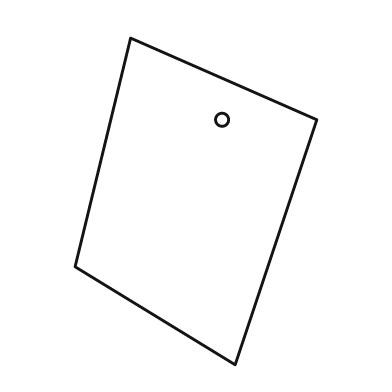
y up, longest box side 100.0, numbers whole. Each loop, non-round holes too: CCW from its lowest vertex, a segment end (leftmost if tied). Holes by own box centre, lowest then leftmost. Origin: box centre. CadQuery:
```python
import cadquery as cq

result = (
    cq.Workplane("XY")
    .moveTo(12.0, -50.0)
    .lineTo(37.0, 25.0)
    .lineTo(-20.0, 50.0)
    .lineTo(-37.0, -20.0)
    .close()
    .moveTo(8.0, 25.0)
    .circle(2.0)
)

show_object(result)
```